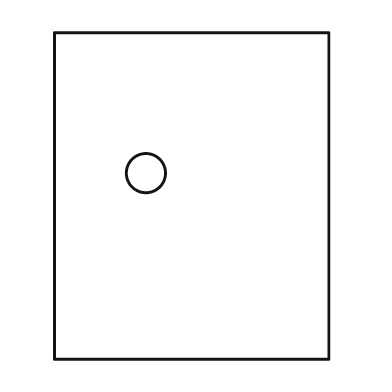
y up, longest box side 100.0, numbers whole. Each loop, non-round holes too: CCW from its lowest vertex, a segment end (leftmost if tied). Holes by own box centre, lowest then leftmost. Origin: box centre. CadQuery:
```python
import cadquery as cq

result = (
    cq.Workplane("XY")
    .moveTo(-42.0, -50.0)
    .lineTo(42.0, -50.0)
    .lineTo(42.0, 50.0)
    .lineTo(-42.0, 50.0)
    .close()
    .moveTo(-14.0, 7.0)
    .circle(6.0)
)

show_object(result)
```